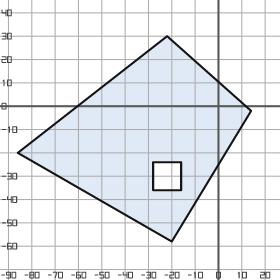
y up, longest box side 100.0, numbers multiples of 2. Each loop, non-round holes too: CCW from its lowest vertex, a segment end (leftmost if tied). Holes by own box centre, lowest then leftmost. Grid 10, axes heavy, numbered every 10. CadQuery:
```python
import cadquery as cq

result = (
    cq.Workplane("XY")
    .moveTo(-20.0, -58.0)
    .lineTo(14.0, -2.0)
    .lineTo(-22.0, 30.0)
    .lineTo(-86.0, -20.0)
    .close()
    .moveTo(-28.0, -36.0)
    .lineTo(-16.0, -36.0)
    .lineTo(-16.0, -24.0)
    .lineTo(-28.0, -24.0)
    .close()
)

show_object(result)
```